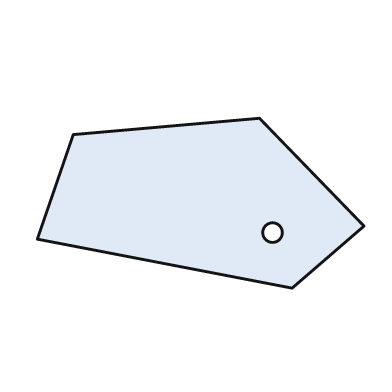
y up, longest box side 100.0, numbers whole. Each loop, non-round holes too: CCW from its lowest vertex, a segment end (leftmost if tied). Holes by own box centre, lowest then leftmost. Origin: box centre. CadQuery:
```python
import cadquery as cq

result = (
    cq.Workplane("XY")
    .moveTo(28.0, -26.0)
    .lineTo(50.0, -7.0)
    .lineTo(18.0, 26.0)
    .lineTo(-39.0, 21.0)
    .lineTo(-50.0, -11.0)
    .close()
    .moveTo(22.0, -9.0)
    .circle(3.0)
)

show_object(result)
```